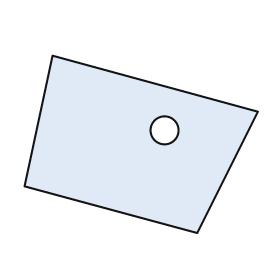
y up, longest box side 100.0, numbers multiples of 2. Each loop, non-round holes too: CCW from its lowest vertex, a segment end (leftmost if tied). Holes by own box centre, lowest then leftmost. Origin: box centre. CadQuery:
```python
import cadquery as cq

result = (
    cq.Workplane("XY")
    .moveTo(24.0, -38.0)
    .lineTo(50.0, 14.0)
    .lineTo(-38.0, 38.0)
    .lineTo(-50.0, -18.0)
    .close()
    .moveTo(10.0, 6.0)
    .circle(6.0)
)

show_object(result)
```